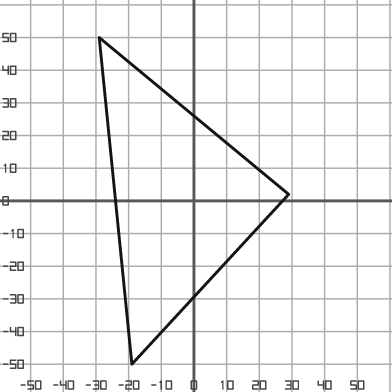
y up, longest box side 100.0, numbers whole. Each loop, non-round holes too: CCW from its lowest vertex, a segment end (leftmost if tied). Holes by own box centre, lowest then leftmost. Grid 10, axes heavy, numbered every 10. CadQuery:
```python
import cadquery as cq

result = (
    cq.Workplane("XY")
    .moveTo(-19.0, -50.0)
    .lineTo(29.0, 2.0)
    .lineTo(-29.0, 50.0)
    .close()
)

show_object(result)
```